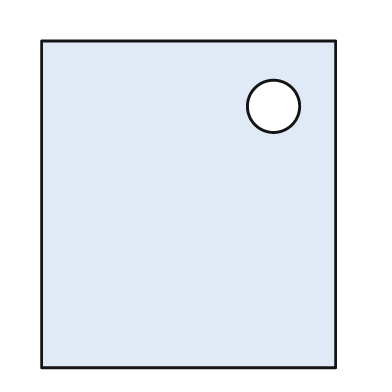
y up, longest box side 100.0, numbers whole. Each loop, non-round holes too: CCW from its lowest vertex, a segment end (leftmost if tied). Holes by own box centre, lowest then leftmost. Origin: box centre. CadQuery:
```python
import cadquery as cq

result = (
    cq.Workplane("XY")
    .moveTo(-45.0, -50.0)
    .lineTo(45.0, -50.0)
    .lineTo(45.0, 50.0)
    .lineTo(-45.0, 50.0)
    .close()
    .moveTo(26.0, 30.0)
    .circle(8.0)
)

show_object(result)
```